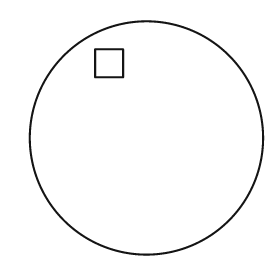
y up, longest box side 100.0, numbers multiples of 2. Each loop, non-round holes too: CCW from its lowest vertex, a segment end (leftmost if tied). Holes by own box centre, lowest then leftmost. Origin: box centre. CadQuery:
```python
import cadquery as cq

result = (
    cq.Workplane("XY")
    .moveTo(0.0, 0.0)
    .circle(50.0)
    .moveTo(-22.0, 26.0)
    .lineTo(-10.0, 26.0)
    .lineTo(-10.0, 38.0)
    .lineTo(-22.0, 38.0)
    .close()
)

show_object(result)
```